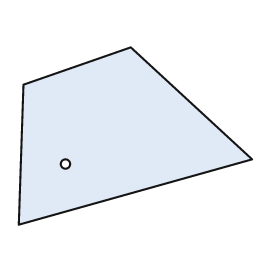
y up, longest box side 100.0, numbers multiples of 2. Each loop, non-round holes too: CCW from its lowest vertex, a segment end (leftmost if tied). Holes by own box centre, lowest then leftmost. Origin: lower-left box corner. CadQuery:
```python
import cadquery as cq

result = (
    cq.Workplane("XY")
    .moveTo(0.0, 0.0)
    .lineTo(100.0, 28.0)
    .lineTo(48.0, 76.0)
    .lineTo(2.0, 60.0)
    .close()
    .moveTo(20.0, 26.0)
    .circle(2.0)
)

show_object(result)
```